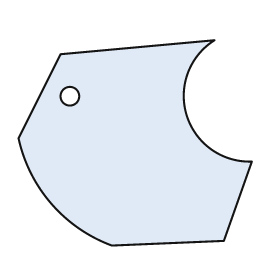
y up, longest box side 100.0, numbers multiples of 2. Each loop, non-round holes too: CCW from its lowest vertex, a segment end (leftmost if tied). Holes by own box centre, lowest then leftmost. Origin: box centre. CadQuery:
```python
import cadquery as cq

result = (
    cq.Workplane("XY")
    .moveTo(-10.0, -44.0)
    .lineTo(38.0, -42.0)
    .lineTo(50.0, -8.0)
    .threePointArc((22.0, 12.0), (34.0, 44.0))
    .lineTo(-32.0, 38.0)
    .lineTo(-50.0, 2.0)
    .threePointArc((-36.0, -26.0), (-10.0, -44.0))
    .close()
    .moveTo(-28.0, 20.0)
    .circle(4.0)
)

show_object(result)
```